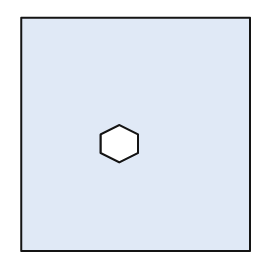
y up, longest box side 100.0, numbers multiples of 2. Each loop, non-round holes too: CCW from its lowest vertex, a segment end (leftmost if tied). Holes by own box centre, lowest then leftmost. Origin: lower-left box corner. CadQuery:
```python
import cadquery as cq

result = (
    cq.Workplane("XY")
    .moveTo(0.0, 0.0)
    .lineTo(98.0, 0.0)
    .lineTo(98.0, 100.0)
    .lineTo(0.0, 100.0)
    .close()
    .moveTo(42.0, 38.0)
    .lineTo(50.0, 42.0)
    .lineTo(50.0, 50.0)
    .lineTo(42.0, 54.0)
    .lineTo(34.0, 50.0)
    .lineTo(34.0, 42.0)
    .close()
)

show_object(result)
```